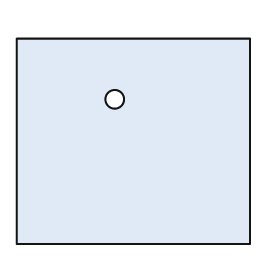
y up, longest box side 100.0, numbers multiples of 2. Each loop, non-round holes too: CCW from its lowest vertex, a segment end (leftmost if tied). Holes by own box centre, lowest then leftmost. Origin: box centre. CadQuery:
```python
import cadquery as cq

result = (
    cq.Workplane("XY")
    .moveTo(-50.0, -44.0)
    .lineTo(50.0, -44.0)
    .lineTo(50.0, 44.0)
    .lineTo(-50.0, 44.0)
    .close()
    .moveTo(-8.0, 18.0)
    .circle(4.0)
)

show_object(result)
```